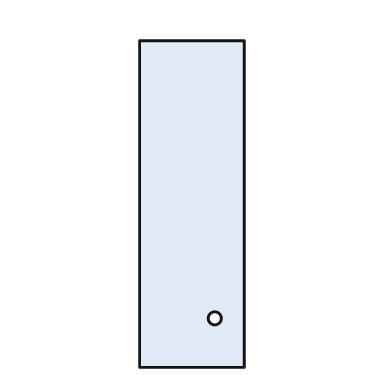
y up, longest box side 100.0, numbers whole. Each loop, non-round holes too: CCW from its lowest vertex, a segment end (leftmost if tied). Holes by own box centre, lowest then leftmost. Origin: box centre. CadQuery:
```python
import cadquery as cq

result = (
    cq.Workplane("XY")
    .moveTo(-16.0, -50.0)
    .lineTo(16.0, -50.0)
    .lineTo(16.0, 50.0)
    .lineTo(-16.0, 50.0)
    .close()
    .moveTo(7.0, -35.0)
    .circle(2.0)
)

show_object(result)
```